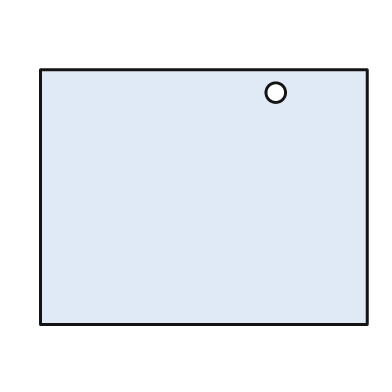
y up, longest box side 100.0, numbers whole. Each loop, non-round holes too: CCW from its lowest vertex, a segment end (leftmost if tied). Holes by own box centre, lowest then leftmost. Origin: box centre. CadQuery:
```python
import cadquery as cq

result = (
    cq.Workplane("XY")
    .moveTo(-50.0, -39.0)
    .lineTo(50.0, -39.0)
    .lineTo(50.0, 39.0)
    .lineTo(-50.0, 39.0)
    .close()
    .moveTo(22.0, 32.0)
    .circle(3.0)
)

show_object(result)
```